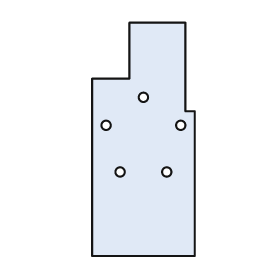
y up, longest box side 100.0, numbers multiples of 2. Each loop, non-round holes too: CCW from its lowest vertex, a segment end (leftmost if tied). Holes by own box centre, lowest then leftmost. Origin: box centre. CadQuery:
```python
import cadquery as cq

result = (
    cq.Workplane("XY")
    .moveTo(-22.0, -50.0)
    .lineTo(22.0, -50.0)
    .lineTo(22.0, 12.0)
    .lineTo(18.0, 12.0)
    .lineTo(18.0, 50.0)
    .lineTo(-6.0, 50.0)
    .lineTo(-6.0, 26.0)
    .lineTo(-22.0, 26.0)
    .close()
    .moveTo(-10.0, -14.0)
    .circle(2.0)
    .moveTo(10.0, -14.0)
    .circle(2.0)
    .moveTo(-16.0, 6.0)
    .circle(2.0)
    .moveTo(16.0, 6.0)
    .circle(2.0)
    .moveTo(0.0, 18.0)
    .circle(2.0)
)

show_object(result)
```